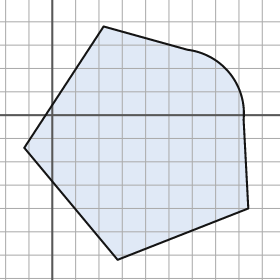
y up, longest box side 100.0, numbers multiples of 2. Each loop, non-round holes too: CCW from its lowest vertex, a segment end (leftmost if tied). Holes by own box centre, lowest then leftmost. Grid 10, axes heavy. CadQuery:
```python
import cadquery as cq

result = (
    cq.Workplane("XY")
    .moveTo(28.0, -62.0)
    .lineTo(84.0, -40.0)
    .lineTo(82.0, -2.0)
    .threePointArc((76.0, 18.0), (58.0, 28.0))
    .lineTo(22.0, 38.0)
    .lineTo(-12.0, -14.0)
    .close()
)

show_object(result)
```